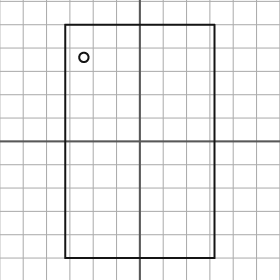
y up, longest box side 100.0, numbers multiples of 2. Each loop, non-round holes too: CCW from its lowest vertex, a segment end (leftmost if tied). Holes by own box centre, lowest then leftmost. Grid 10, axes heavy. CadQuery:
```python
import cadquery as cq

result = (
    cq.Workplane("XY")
    .moveTo(-32.0, -50.0)
    .lineTo(32.0, -50.0)
    .lineTo(32.0, 50.0)
    .lineTo(-32.0, 50.0)
    .close()
    .moveTo(-24.0, 36.0)
    .circle(2.0)
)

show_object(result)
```